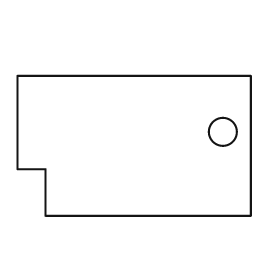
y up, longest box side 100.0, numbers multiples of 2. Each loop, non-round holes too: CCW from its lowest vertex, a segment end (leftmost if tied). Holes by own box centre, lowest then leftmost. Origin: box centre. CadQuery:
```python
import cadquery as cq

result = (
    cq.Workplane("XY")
    .moveTo(-38.0, -30.0)
    .lineTo(50.0, -30.0)
    .lineTo(50.0, 30.0)
    .lineTo(-50.0, 30.0)
    .lineTo(-50.0, -10.0)
    .lineTo(-38.0, -10.0)
    .close()
    .moveTo(38.0, 6.0)
    .circle(6.0)
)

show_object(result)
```